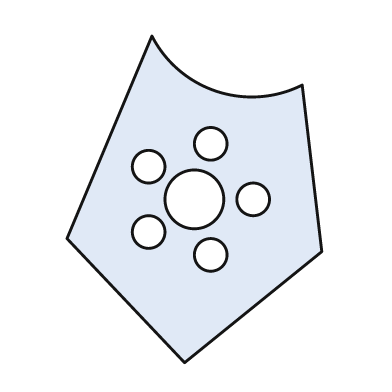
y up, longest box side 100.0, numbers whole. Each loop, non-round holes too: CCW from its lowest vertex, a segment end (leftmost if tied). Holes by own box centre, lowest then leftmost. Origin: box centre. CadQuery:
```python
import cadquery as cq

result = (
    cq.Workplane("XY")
    .moveTo(-3.0, -50.0)
    .lineTo(39.0, -16.0)
    .lineTo(33.0, 35.0)
    .threePointArc((7.0, 33.0), (-13.0, 50.0))
    .lineTo(-39.0, -12.0)
    .close()
    .moveTo(5.0, -17.0)
    .circle(5.0)
    .moveTo(-14.0, -10.0)
    .circle(5.0)
    .moveTo(0.0, 0.0)
    .circle(9.0)
    .moveTo(18.0, 0.0)
    .circle(5.0)
    .moveTo(-14.0, 10.0)
    .circle(5.0)
    .moveTo(5.0, 17.0)
    .circle(5.0)
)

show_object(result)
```